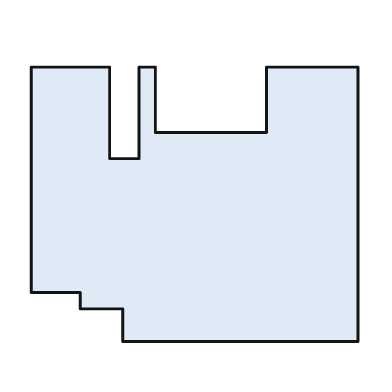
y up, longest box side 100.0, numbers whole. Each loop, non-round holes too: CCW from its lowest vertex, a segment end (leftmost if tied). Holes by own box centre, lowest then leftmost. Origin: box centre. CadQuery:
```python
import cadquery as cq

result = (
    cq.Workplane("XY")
    .moveTo(-22.0, -42.0)
    .lineTo(50.0, -42.0)
    .lineTo(50.0, 42.0)
    .lineTo(22.0, 42.0)
    .lineTo(22.0, 22.0)
    .lineTo(-12.0, 22.0)
    .lineTo(-12.0, 42.0)
    .lineTo(-17.0, 42.0)
    .lineTo(-17.0, 14.0)
    .lineTo(-26.0, 14.0)
    .lineTo(-26.0, 42.0)
    .lineTo(-50.0, 42.0)
    .lineTo(-50.0, -27.0)
    .lineTo(-35.0, -27.0)
    .lineTo(-35.0, -32.0)
    .lineTo(-22.0, -32.0)
    .close()
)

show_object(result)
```